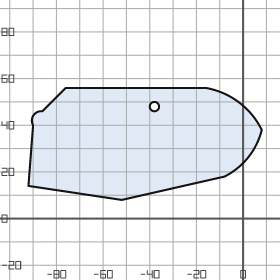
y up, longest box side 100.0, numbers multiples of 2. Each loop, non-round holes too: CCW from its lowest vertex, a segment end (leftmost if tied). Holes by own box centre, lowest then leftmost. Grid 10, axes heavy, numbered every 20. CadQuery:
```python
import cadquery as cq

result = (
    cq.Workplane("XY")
    .moveTo(-52.0, 8.0)
    .lineTo(-8.0, 18.0)
    .threePointArc((2.0, 26.0), (8.0, 38.0))
    .threePointArc((-2.0, 50.0), (-16.0, 56.0))
    .lineTo(-76.0, 56.0)
    .lineTo(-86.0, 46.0)
    .threePointArc((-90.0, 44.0), (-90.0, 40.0))
    .lineTo(-92.0, 14.0)
    .close()
    .moveTo(-38.0, 48.0)
    .circle(2.0)
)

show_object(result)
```